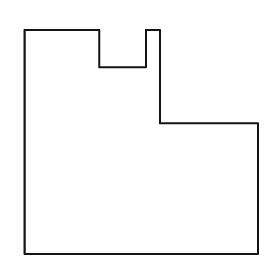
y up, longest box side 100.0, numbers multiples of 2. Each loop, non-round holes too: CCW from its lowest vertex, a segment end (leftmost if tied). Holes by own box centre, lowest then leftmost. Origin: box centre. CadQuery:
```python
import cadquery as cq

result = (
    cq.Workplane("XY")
    .moveTo(-50.0, -48.0)
    .lineTo(50.0, -48.0)
    .lineTo(50.0, 8.0)
    .lineTo(8.0, 8.0)
    .lineTo(8.0, 48.0)
    .lineTo(2.0, 48.0)
    .lineTo(2.0, 32.0)
    .lineTo(-18.0, 32.0)
    .lineTo(-18.0, 48.0)
    .lineTo(-50.0, 48.0)
    .close()
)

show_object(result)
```